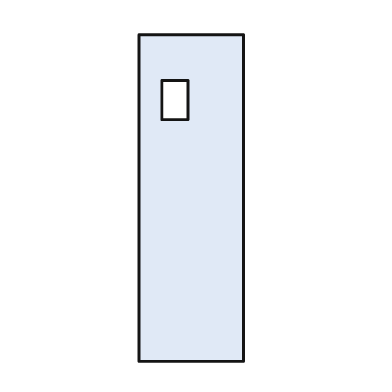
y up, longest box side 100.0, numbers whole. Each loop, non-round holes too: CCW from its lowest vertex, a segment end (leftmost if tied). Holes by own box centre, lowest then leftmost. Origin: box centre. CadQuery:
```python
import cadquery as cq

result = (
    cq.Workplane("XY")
    .moveTo(-16.0, -50.0)
    .lineTo(16.0, -50.0)
    .lineTo(16.0, 50.0)
    .lineTo(-16.0, 50.0)
    .close()
    .moveTo(-9.0, 24.0)
    .lineTo(-1.0, 24.0)
    .lineTo(-1.0, 36.0)
    .lineTo(-9.0, 36.0)
    .close()
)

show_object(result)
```